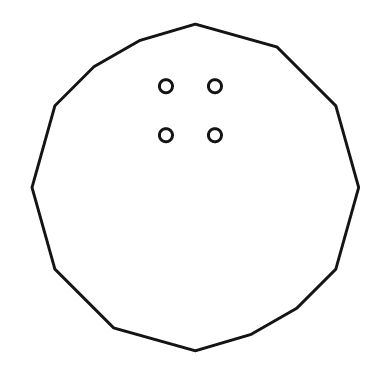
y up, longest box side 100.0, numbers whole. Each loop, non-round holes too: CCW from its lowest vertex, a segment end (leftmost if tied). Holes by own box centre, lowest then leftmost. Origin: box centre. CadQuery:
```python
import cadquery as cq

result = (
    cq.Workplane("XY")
    .moveTo(0.0, -50.0)
    .lineTo(17.0, -45.0)
    .lineTo(31.0, -37.0)
    .lineTo(43.0, -25.0)
    .lineTo(50.0, 0.0)
    .lineTo(43.0, 25.0)
    .lineTo(25.0, 43.0)
    .lineTo(0.0, 50.0)
    .lineTo(-17.0, 45.0)
    .lineTo(-31.0, 37.0)
    .lineTo(-43.0, 25.0)
    .lineTo(-50.0, 0.0)
    .lineTo(-43.0, -25.0)
    .lineTo(-25.0, -43.0)
    .close()
    .moveTo(-9.0, 16.0)
    .circle(2.0)
    .moveTo(6.0, 16.0)
    .circle(2.0)
    .moveTo(-9.0, 31.0)
    .circle(2.0)
    .moveTo(6.0, 31.0)
    .circle(2.0)
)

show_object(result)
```